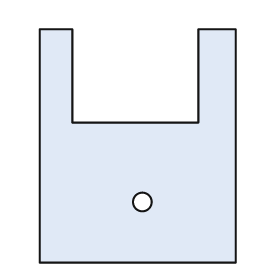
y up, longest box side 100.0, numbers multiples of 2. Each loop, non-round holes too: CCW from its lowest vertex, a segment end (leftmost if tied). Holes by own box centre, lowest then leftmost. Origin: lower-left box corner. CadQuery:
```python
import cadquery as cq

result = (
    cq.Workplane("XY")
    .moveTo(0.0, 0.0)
    .lineTo(84.0, 0.0)
    .lineTo(84.0, 100.0)
    .lineTo(68.0, 100.0)
    .lineTo(68.0, 60.0)
    .lineTo(14.0, 60.0)
    .lineTo(14.0, 100.0)
    .lineTo(0.0, 100.0)
    .close()
    .moveTo(44.0, 26.0)
    .circle(4.0)
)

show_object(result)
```